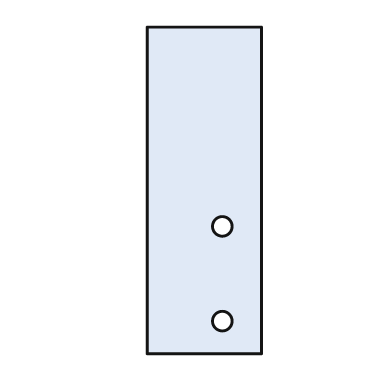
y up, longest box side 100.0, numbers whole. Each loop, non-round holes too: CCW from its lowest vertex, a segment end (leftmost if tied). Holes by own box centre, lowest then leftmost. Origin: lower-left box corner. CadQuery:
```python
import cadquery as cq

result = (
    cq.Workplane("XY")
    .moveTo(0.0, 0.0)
    .lineTo(35.0, 0.0)
    .lineTo(35.0, 100.0)
    .lineTo(0.0, 100.0)
    .close()
    .moveTo(23.0, 10.0)
    .circle(3.0)
    .moveTo(23.0, 39.0)
    .circle(3.0)
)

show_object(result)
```